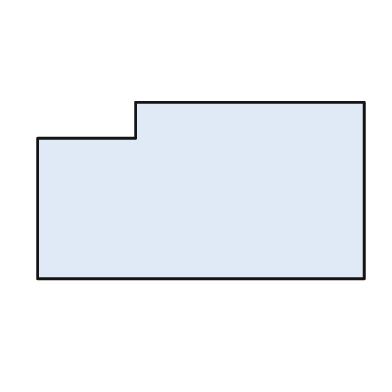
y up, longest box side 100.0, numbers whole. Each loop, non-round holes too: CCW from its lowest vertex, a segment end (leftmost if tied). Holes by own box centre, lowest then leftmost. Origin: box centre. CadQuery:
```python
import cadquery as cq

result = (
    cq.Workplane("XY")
    .moveTo(-50.0, -27.0)
    .lineTo(50.0, -27.0)
    .lineTo(50.0, 27.0)
    .lineTo(-20.0, 27.0)
    .lineTo(-20.0, 16.0)
    .lineTo(-50.0, 16.0)
    .close()
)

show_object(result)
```